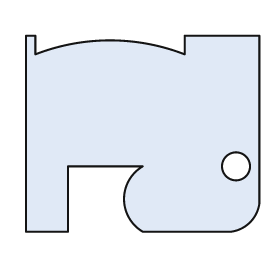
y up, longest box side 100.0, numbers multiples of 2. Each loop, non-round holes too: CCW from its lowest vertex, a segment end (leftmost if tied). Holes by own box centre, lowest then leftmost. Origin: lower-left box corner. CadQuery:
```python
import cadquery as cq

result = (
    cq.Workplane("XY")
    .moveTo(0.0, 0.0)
    .lineTo(18.0, 0.0)
    .lineTo(18.0, 28.0)
    .lineTo(50.0, 28.0)
    .threePointArc((42.0, 14.0), (50.0, 0.0))
    .lineTo(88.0, 0.0)
    .threePointArc((96.0, 4.0), (100.0, 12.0))
    .lineTo(100.0, 84.0)
    .lineTo(68.0, 84.0)
    .lineTo(68.0, 76.0)
    .threePointArc((36.0, 82.0), (4.0, 76.0))
    .lineTo(4.0, 84.0)
    .lineTo(0.0, 84.0)
    .close()
    .moveTo(90.0, 28.0)
    .circle(6.0)
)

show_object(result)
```